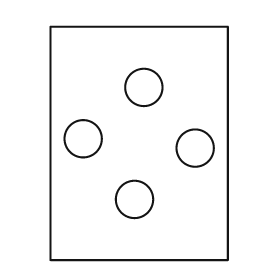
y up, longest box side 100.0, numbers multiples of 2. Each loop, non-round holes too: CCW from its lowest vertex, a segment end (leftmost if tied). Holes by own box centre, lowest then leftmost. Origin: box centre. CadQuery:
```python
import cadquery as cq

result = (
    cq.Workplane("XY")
    .moveTo(-38.0, -50.0)
    .lineTo(38.0, -50.0)
    .lineTo(38.0, 50.0)
    .lineTo(-38.0, 50.0)
    .close()
    .moveTo(-2.0, -24.0)
    .circle(8.0)
    .moveTo(24.0, -2.0)
    .circle(8.0)
    .moveTo(-24.0, 2.0)
    .circle(8.0)
    .moveTo(2.0, 24.0)
    .circle(8.0)
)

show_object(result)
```